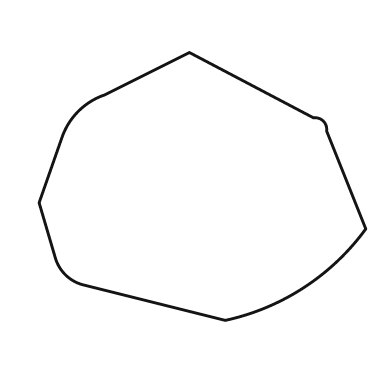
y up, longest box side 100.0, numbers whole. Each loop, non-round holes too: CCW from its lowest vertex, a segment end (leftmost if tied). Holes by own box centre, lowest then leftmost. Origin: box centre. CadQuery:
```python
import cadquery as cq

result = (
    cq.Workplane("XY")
    .moveTo(7.0, -41.0)
    .threePointArc((31.0, -31.0), (50.0, -13.0))
    .lineTo(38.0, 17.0)
    .threePointArc((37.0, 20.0), (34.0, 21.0))
    .lineTo(-4.0, 41.0)
    .lineTo(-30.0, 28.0)
    .threePointArc((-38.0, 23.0), (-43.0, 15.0))
    .lineTo(-50.0, -5.0)
    .lineTo(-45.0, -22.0)
    .threePointArc((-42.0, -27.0), (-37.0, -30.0))
    .close()
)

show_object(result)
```